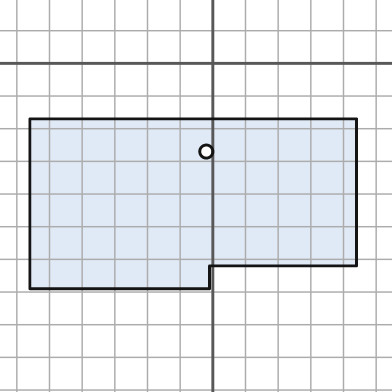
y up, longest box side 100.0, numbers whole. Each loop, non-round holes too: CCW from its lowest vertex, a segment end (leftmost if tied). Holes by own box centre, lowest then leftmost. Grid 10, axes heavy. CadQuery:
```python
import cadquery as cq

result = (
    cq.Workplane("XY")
    .moveTo(-56.0, -69.0)
    .lineTo(-1.0, -69.0)
    .lineTo(-1.0, -62.0)
    .lineTo(44.0, -62.0)
    .lineTo(44.0, -17.0)
    .lineTo(-56.0, -17.0)
    .close()
    .moveTo(-2.0, -27.0)
    .circle(2.0)
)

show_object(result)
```